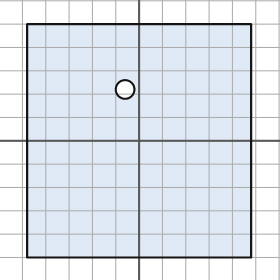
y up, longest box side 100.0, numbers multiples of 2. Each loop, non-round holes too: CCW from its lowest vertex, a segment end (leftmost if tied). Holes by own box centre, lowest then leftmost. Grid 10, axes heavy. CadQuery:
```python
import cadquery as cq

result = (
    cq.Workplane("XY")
    .moveTo(-48.0, -50.0)
    .lineTo(48.0, -50.0)
    .lineTo(48.0, 50.0)
    .lineTo(-48.0, 50.0)
    .close()
    .moveTo(-6.0, 22.0)
    .circle(4.0)
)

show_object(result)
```